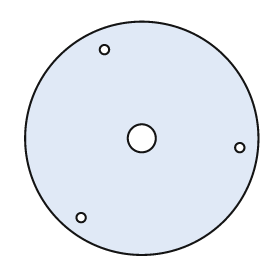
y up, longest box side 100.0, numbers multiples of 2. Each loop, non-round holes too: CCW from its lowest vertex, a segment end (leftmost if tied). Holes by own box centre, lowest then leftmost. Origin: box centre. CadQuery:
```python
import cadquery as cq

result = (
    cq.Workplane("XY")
    .moveTo(0.0, 0.0)
    .circle(50.0)
    .moveTo(-26.0, -34.0)
    .circle(2.0)
    .moveTo(42.0, -4.0)
    .circle(2.0)
    .moveTo(0.0, 0.0)
    .circle(6.0)
    .moveTo(-16.0, 38.0)
    .circle(2.0)
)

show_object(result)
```